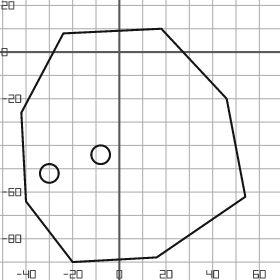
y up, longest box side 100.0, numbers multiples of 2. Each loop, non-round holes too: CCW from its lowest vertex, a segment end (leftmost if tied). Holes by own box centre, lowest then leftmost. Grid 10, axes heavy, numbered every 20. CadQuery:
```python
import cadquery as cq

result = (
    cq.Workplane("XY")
    .moveTo(-20.0, -90.0)
    .lineTo(16.0, -88.0)
    .lineTo(54.0, -62.0)
    .lineTo(46.0, -20.0)
    .lineTo(18.0, 10.0)
    .lineTo(-24.0, 8.0)
    .lineTo(-42.0, -26.0)
    .lineTo(-40.0, -64.0)
    .close()
    .moveTo(-30.0, -52.0)
    .circle(4.0)
    .moveTo(-8.0, -44.0)
    .circle(4.0)
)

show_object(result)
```